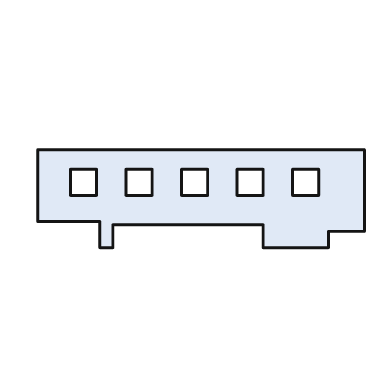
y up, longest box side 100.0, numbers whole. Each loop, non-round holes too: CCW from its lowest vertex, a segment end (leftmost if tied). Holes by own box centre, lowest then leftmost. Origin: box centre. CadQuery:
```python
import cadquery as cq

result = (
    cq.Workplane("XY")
    .moveTo(-31.0, -15.0)
    .lineTo(-27.0, -15.0)
    .lineTo(-27.0, -8.0)
    .lineTo(19.0, -8.0)
    .lineTo(19.0, -15.0)
    .lineTo(39.0, -15.0)
    .lineTo(39.0, -10.0)
    .lineTo(50.0, -10.0)
    .lineTo(50.0, 15.0)
    .lineTo(-50.0, 15.0)
    .lineTo(-50.0, -7.0)
    .lineTo(-31.0, -7.0)
    .close()
    .moveTo(-40.0, 1.0)
    .lineTo(-32.0, 1.0)
    .lineTo(-32.0, 9.0)
    .lineTo(-40.0, 9.0)
    .close()
    .moveTo(-23.0, 1.0)
    .lineTo(-15.0, 1.0)
    .lineTo(-15.0, 9.0)
    .lineTo(-23.0, 9.0)
    .close()
    .moveTo(-6.0, 1.0)
    .lineTo(2.0, 1.0)
    .lineTo(2.0, 9.0)
    .lineTo(-6.0, 9.0)
    .close()
    .moveTo(11.0, 1.0)
    .lineTo(19.0, 1.0)
    .lineTo(19.0, 9.0)
    .lineTo(11.0, 9.0)
    .close()
    .moveTo(28.0, 1.0)
    .lineTo(36.0, 1.0)
    .lineTo(36.0, 9.0)
    .lineTo(28.0, 9.0)
    .close()
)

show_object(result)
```